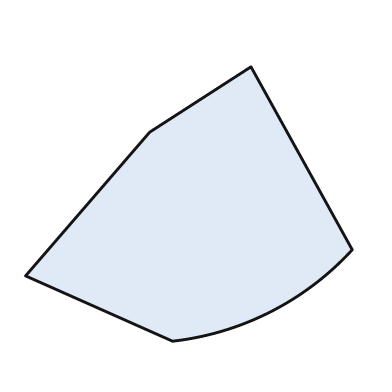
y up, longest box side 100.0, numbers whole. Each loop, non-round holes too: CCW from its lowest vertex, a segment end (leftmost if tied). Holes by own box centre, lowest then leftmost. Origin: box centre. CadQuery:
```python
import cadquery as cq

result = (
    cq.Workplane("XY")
    .moveTo(-5.0, -42.0)
    .threePointArc((25.0, -33.0), (50.0, -14.0))
    .lineTo(19.0, 42.0)
    .lineTo(-12.0, 22.0)
    .lineTo(-50.0, -22.0)
    .close()
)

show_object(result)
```